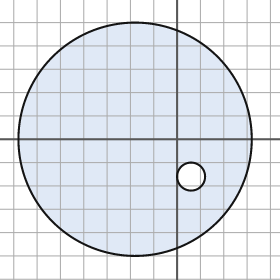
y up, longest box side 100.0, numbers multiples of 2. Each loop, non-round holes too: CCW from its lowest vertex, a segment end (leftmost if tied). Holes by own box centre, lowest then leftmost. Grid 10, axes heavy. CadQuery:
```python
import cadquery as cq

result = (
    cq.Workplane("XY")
    .moveTo(-18.0, 0.0)
    .circle(50.0)
    .moveTo(6.0, -16.0)
    .circle(6.0)
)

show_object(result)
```